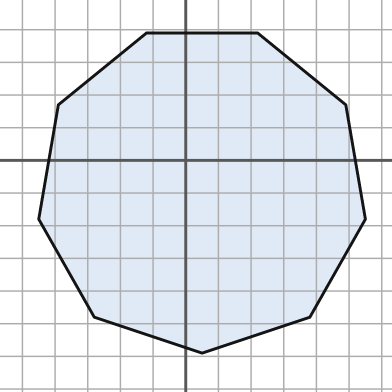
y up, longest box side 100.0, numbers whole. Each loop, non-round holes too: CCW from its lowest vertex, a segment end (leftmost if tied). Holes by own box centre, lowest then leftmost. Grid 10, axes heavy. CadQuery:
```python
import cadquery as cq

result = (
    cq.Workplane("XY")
    .moveTo(5.0, -59.0)
    .lineTo(38.0, -48.0)
    .lineTo(55.0, -18.0)
    .lineTo(49.0, 17.0)
    .lineTo(22.0, 39.0)
    .lineTo(-12.0, 39.0)
    .lineTo(-39.0, 17.0)
    .lineTo(-45.0, -18.0)
    .lineTo(-28.0, -48.0)
    .close()
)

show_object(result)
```